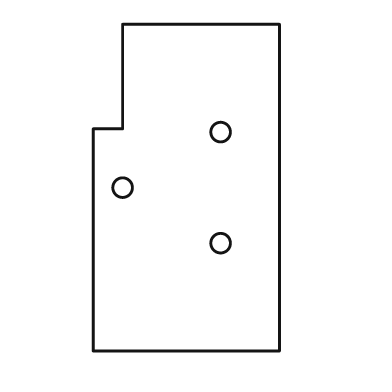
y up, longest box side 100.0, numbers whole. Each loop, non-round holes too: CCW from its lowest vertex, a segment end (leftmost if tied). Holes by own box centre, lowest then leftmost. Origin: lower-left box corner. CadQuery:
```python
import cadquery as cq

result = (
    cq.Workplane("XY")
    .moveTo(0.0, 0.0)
    .lineTo(57.0, 0.0)
    .lineTo(57.0, 100.0)
    .lineTo(9.0, 100.0)
    .lineTo(9.0, 68.0)
    .lineTo(0.0, 68.0)
    .close()
    .moveTo(39.0, 33.0)
    .circle(3.0)
    .moveTo(9.0, 50.0)
    .circle(3.0)
    .moveTo(39.0, 67.0)
    .circle(3.0)
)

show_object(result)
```